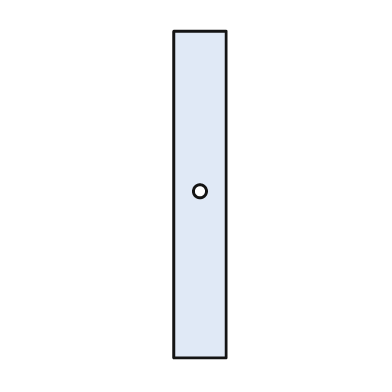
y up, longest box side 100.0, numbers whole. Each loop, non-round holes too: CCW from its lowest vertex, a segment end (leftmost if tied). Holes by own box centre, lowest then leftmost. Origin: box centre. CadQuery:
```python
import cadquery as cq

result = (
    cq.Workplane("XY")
    .moveTo(-8.0, -50.0)
    .lineTo(8.0, -50.0)
    .lineTo(8.0, 50.0)
    .lineTo(-8.0, 50.0)
    .close()
    .moveTo(0.0, 1.0)
    .circle(2.0)
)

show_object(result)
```